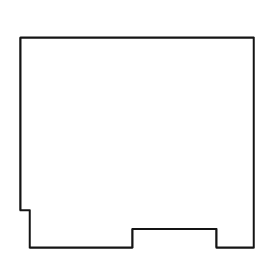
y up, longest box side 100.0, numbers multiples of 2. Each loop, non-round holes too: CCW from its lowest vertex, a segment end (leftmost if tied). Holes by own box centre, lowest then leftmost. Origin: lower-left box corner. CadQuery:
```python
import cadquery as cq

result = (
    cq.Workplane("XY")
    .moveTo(4.0, 0.0)
    .lineTo(48.0, 0.0)
    .lineTo(48.0, 8.0)
    .lineTo(84.0, 8.0)
    .lineTo(84.0, 0.0)
    .lineTo(100.0, 0.0)
    .lineTo(100.0, 90.0)
    .lineTo(0.0, 90.0)
    .lineTo(0.0, 16.0)
    .lineTo(4.0, 16.0)
    .close()
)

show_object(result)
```